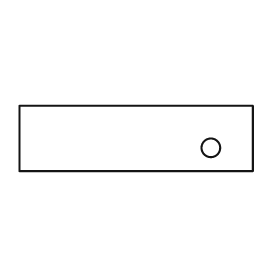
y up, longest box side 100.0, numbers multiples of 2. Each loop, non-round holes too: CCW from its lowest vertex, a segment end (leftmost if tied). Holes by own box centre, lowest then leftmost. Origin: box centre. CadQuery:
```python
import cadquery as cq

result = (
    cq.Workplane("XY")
    .moveTo(-50.0, -14.0)
    .lineTo(50.0, -14.0)
    .lineTo(50.0, 14.0)
    .lineTo(-50.0, 14.0)
    .close()
    .moveTo(32.0, -4.0)
    .circle(4.0)
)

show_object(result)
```